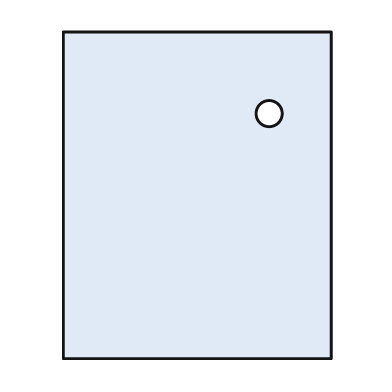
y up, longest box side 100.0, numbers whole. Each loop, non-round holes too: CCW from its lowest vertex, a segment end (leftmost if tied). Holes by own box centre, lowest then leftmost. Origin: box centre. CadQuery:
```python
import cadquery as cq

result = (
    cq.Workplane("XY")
    .moveTo(-41.0, -50.0)
    .lineTo(41.0, -50.0)
    .lineTo(41.0, 50.0)
    .lineTo(-41.0, 50.0)
    .close()
    .moveTo(22.0, 25.0)
    .circle(4.0)
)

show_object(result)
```